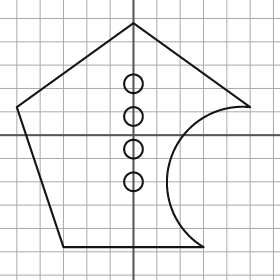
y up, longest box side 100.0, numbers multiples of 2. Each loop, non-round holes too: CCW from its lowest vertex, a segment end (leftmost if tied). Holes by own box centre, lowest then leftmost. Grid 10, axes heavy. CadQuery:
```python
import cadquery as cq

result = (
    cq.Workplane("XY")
    .moveTo(-30.0, -48.0)
    .lineTo(30.0, -48.0)
    .threePointArc((16.0, -10.0), (50.0, 12.0))
    .lineTo(0.0, 48.0)
    .lineTo(-50.0, 12.0)
    .close()
    .moveTo(0.0, -20.0)
    .circle(4.0)
    .moveTo(0.0, -6.0)
    .circle(4.0)
    .moveTo(0.0, 8.0)
    .circle(4.0)
    .moveTo(0.0, 22.0)
    .circle(4.0)
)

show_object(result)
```